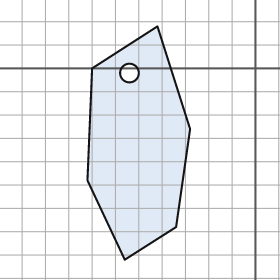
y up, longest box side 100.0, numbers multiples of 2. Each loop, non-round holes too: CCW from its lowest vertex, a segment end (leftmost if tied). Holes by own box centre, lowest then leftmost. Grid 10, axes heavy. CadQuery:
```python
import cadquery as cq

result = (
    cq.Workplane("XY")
    .moveTo(-56.0, -82.0)
    .lineTo(-34.0, -68.0)
    .lineTo(-28.0, -26.0)
    .lineTo(-42.0, 18.0)
    .lineTo(-70.0, 0.0)
    .lineTo(-72.0, -48.0)
    .close()
    .moveTo(-54.0, -2.0)
    .circle(4.0)
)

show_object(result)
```